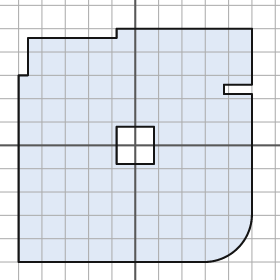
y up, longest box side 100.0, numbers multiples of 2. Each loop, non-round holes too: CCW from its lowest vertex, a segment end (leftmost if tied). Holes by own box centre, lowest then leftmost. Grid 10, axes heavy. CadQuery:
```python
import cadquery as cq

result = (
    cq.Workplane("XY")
    .moveTo(-50.0, -50.0)
    .lineTo(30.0, -50.0)
    .threePointArc((44.0, -44.0), (50.0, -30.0))
    .lineTo(50.0, 22.0)
    .lineTo(38.0, 22.0)
    .lineTo(38.0, 26.0)
    .lineTo(50.0, 26.0)
    .lineTo(50.0, 50.0)
    .lineTo(-8.0, 50.0)
    .lineTo(-8.0, 46.0)
    .lineTo(-46.0, 46.0)
    .lineTo(-46.0, 30.0)
    .lineTo(-50.0, 30.0)
    .close()
    .moveTo(-8.0, -8.0)
    .lineTo(8.0, -8.0)
    .lineTo(8.0, 8.0)
    .lineTo(-8.0, 8.0)
    .close()
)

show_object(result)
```